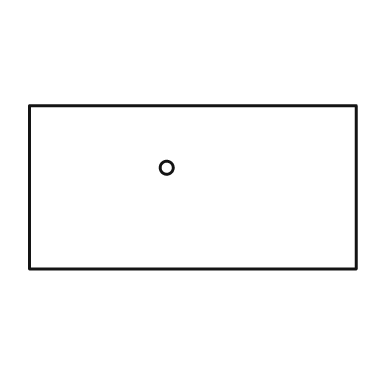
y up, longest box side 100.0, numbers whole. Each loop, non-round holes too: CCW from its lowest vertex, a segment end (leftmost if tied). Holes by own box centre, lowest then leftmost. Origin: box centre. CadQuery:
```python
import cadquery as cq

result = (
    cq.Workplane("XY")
    .moveTo(-50.0, -25.0)
    .lineTo(50.0, -25.0)
    .lineTo(50.0, 25.0)
    .lineTo(-50.0, 25.0)
    .close()
    .moveTo(-8.0, 6.0)
    .circle(2.0)
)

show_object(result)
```